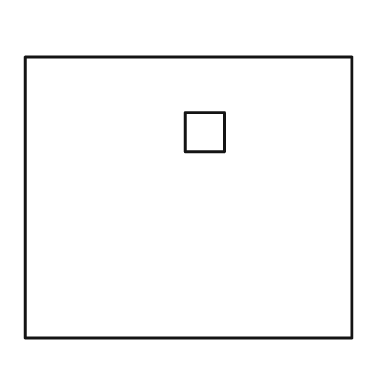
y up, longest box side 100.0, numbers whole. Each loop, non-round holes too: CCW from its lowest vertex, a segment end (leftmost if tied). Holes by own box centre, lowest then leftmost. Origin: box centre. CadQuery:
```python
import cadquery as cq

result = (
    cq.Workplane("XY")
    .moveTo(-50.0, -43.0)
    .lineTo(50.0, -43.0)
    .lineTo(50.0, 43.0)
    .lineTo(-50.0, 43.0)
    .close()
    .moveTo(-1.0, 14.0)
    .lineTo(11.0, 14.0)
    .lineTo(11.0, 26.0)
    .lineTo(-1.0, 26.0)
    .close()
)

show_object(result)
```